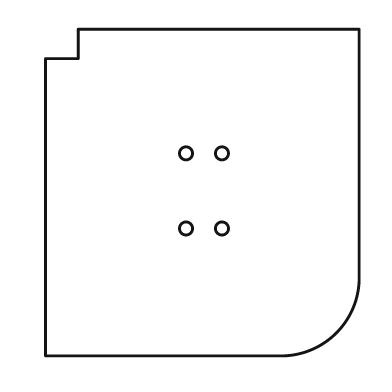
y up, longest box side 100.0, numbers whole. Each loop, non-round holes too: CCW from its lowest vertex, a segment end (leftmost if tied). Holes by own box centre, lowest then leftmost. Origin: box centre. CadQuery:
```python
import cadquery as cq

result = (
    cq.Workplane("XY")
    .moveTo(-48.0, -50.0)
    .lineTo(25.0, -50.0)
    .threePointArc((41.0, -43.0), (48.0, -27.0))
    .lineTo(48.0, 50.0)
    .lineTo(-38.0, 50.0)
    .lineTo(-38.0, 41.0)
    .lineTo(-48.0, 41.0)
    .close()
    .moveTo(-5.0, -11.0)
    .circle(2.0)
    .moveTo(6.0, -11.0)
    .circle(2.0)
    .moveTo(-5.0, 12.0)
    .circle(2.0)
    .moveTo(6.0, 12.0)
    .circle(2.0)
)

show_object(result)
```